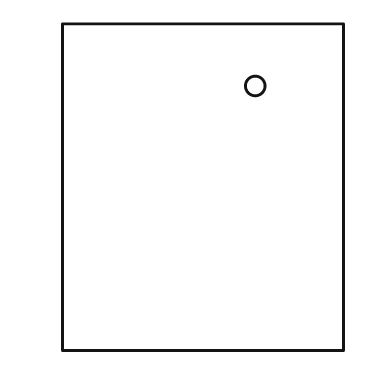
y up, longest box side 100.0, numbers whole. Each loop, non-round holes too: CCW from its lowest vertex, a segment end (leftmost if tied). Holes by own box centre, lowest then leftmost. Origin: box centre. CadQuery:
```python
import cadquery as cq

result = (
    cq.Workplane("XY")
    .moveTo(-43.0, -50.0)
    .lineTo(43.0, -50.0)
    .lineTo(43.0, 50.0)
    .lineTo(-43.0, 50.0)
    .close()
    .moveTo(16.0, 31.0)
    .circle(3.0)
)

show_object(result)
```